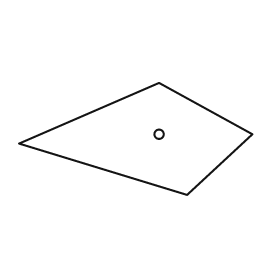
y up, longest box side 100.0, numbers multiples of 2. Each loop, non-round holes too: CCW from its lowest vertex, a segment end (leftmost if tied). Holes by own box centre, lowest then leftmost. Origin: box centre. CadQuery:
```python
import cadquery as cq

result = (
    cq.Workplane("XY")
    .moveTo(22.0, -24.0)
    .lineTo(50.0, 2.0)
    .lineTo(10.0, 24.0)
    .lineTo(-50.0, -2.0)
    .close()
    .moveTo(10.0, 2.0)
    .circle(2.0)
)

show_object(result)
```